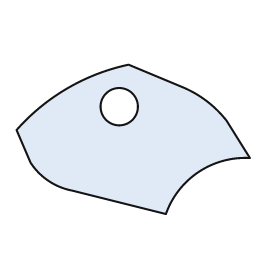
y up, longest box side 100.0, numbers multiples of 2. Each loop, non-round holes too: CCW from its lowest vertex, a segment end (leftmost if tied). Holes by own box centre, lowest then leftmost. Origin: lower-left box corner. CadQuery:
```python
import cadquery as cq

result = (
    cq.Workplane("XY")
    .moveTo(64.0, 0.0)
    .threePointArc((78.0, 18.0), (100.0, 24.0))
    .lineTo(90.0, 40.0)
    .threePointArc((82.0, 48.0), (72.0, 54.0))
    .lineTo(48.0, 64.0)
    .threePointArc((22.0, 54.0), (0.0, 36.0))
    .lineTo(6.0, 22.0)
    .threePointArc((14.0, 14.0), (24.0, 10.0))
    .close()
    .moveTo(44.0, 46.0)
    .circle(8.0)
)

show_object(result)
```